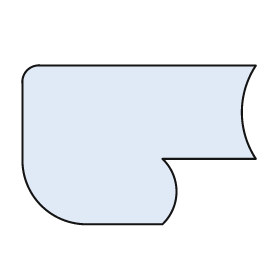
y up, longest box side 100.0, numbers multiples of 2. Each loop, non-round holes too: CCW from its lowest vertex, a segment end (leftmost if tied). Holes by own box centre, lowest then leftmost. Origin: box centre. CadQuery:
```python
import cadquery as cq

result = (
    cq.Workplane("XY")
    .moveTo(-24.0, -34.0)
    .lineTo(10.0, -34.0)
    .threePointArc((16.0, -20.0), (10.0, -6.0))
    .lineTo(50.0, -6.0)
    .threePointArc((44.0, 14.0), (50.0, 34.0))
    .lineTo(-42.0, 34.0)
    .threePointArc((-48.0, 32.0), (-50.0, 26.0))
    .lineTo(-50.0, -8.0)
    .threePointArc((-42.0, -26.0), (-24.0, -34.0))
    .close()
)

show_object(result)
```